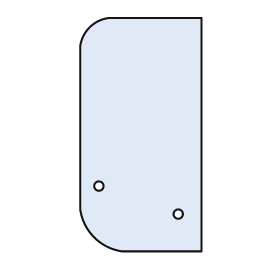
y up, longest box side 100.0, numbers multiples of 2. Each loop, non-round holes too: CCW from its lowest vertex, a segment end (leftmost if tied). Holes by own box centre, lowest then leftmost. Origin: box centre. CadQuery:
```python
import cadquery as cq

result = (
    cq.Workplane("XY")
    .moveTo(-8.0, -50.0)
    .lineTo(26.0, -50.0)
    .lineTo(26.0, 50.0)
    .lineTo(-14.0, 50.0)
    .threePointArc((-22.0, 46.0), (-26.0, 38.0))
    .lineTo(-26.0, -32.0)
    .threePointArc((-20.0, -44.0), (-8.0, -50.0))
    .close()
    .moveTo(16.0, -34.0)
    .circle(2.0)
    .moveTo(-18.0, -22.0)
    .circle(2.0)
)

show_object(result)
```